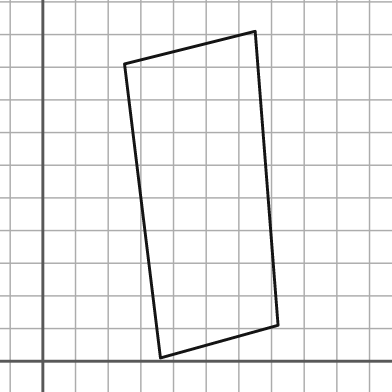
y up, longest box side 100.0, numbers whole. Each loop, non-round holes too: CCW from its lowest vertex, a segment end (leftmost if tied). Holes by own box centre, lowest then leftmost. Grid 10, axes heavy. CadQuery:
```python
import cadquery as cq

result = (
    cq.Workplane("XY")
    .moveTo(36.0, 1.0)
    .lineTo(72.0, 11.0)
    .lineTo(65.0, 101.0)
    .lineTo(25.0, 91.0)
    .close()
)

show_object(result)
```